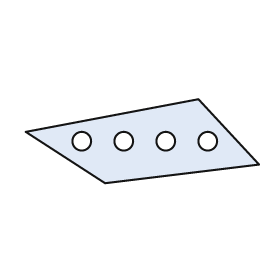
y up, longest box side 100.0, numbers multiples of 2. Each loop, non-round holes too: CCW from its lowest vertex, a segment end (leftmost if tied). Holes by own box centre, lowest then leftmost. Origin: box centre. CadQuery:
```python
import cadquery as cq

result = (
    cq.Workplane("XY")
    .moveTo(-16.0, -18.0)
    .lineTo(50.0, -10.0)
    .lineTo(24.0, 18.0)
    .lineTo(-50.0, 4.0)
    .close()
    .moveTo(-26.0, 0.0)
    .circle(4.0)
    .moveTo(-8.0, 0.0)
    .circle(4.0)
    .moveTo(10.0, 0.0)
    .circle(4.0)
    .moveTo(28.0, 0.0)
    .circle(4.0)
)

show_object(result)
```